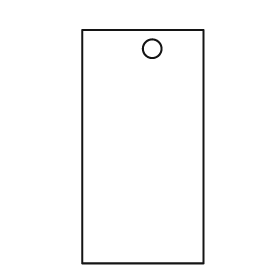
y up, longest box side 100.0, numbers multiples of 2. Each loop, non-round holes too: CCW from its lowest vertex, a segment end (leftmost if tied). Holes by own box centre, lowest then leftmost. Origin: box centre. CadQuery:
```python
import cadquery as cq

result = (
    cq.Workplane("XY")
    .moveTo(-26.0, -50.0)
    .lineTo(26.0, -50.0)
    .lineTo(26.0, 50.0)
    .lineTo(-26.0, 50.0)
    .close()
    .moveTo(4.0, 42.0)
    .circle(4.0)
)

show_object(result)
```